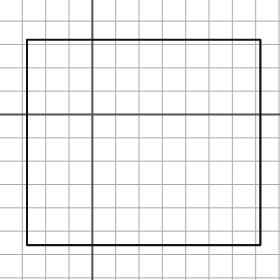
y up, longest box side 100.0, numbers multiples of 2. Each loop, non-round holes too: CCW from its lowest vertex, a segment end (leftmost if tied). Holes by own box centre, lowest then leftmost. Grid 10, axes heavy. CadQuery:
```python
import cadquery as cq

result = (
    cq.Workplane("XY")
    .moveTo(-28.0, -56.0)
    .lineTo(72.0, -56.0)
    .lineTo(72.0, 32.0)
    .lineTo(-28.0, 32.0)
    .close()
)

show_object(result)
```